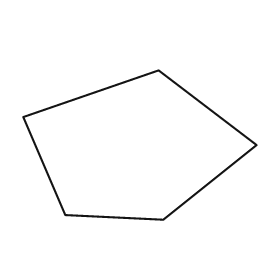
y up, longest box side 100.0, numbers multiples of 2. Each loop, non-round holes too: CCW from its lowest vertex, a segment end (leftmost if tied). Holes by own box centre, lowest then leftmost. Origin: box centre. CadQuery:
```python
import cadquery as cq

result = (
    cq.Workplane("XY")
    .moveTo(10.0, -32.0)
    .lineTo(50.0, 0.0)
    .lineTo(8.0, 32.0)
    .lineTo(-50.0, 12.0)
    .lineTo(-32.0, -30.0)
    .close()
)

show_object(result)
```